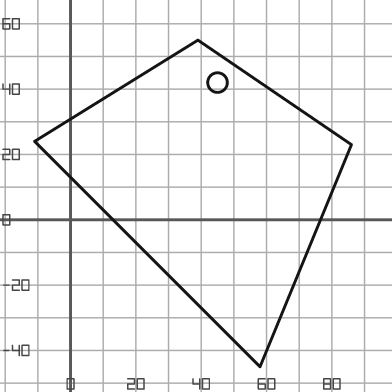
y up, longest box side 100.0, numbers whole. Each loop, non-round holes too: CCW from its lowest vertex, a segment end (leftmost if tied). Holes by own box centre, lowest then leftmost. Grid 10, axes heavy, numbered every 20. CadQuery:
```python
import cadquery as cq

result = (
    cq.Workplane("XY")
    .moveTo(58.0, -45.0)
    .lineTo(86.0, 23.0)
    .lineTo(39.0, 55.0)
    .lineTo(-11.0, 24.0)
    .close()
    .moveTo(45.0, 42.0)
    .circle(3.0)
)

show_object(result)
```